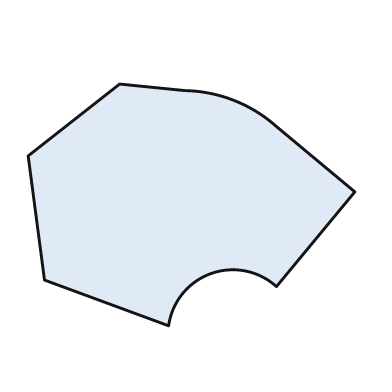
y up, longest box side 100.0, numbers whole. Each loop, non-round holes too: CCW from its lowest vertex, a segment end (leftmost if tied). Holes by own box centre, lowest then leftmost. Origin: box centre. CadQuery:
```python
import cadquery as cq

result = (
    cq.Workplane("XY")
    .moveTo(-7.0, -37.0)
    .threePointArc((6.0, -21.0), (26.0, -25.0))
    .lineTo(50.0, 4.0)
    .lineTo(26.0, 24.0)
    .threePointArc((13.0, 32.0), (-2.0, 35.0))
    .lineTo(-22.0, 37.0)
    .lineTo(-50.0, 15.0)
    .lineTo(-45.0, -23.0)
    .close()
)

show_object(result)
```